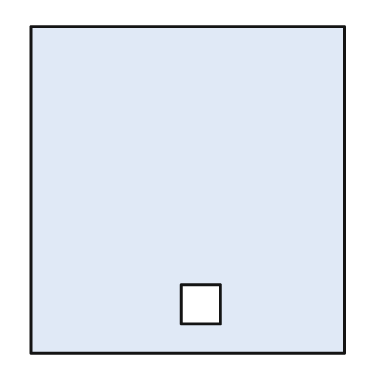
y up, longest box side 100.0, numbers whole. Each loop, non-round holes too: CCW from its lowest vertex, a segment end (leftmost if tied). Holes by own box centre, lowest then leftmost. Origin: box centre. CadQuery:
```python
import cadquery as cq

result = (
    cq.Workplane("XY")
    .moveTo(-48.0, -50.0)
    .lineTo(48.0, -50.0)
    .lineTo(48.0, 50.0)
    .lineTo(-48.0, 50.0)
    .close()
    .moveTo(-2.0, -41.0)
    .lineTo(10.0, -41.0)
    .lineTo(10.0, -29.0)
    .lineTo(-2.0, -29.0)
    .close()
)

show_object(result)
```